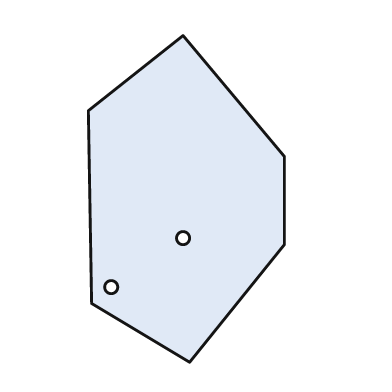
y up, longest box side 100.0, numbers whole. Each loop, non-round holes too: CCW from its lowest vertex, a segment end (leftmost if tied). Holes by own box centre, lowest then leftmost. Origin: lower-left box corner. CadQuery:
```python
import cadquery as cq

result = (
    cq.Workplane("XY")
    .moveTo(31.0, 0.0)
    .lineTo(60.0, 36.0)
    .lineTo(60.0, 63.0)
    .lineTo(29.0, 100.0)
    .lineTo(0.0, 77.0)
    .lineTo(1.0, 18.0)
    .close()
    .moveTo(7.0, 23.0)
    .circle(2.0)
    .moveTo(29.0, 38.0)
    .circle(2.0)
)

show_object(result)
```